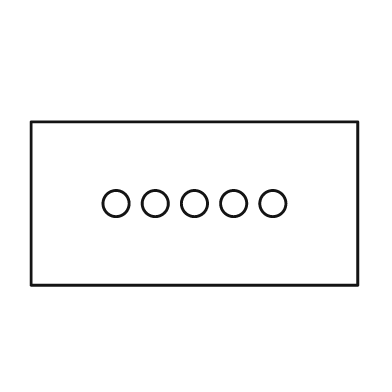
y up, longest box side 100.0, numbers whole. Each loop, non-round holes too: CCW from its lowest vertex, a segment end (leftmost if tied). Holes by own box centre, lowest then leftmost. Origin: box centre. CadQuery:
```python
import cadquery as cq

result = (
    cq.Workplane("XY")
    .moveTo(-50.0, -25.0)
    .lineTo(50.0, -25.0)
    .lineTo(50.0, 25.0)
    .lineTo(-50.0, 25.0)
    .close()
    .moveTo(-24.0, 0.0)
    .circle(4.0)
    .moveTo(-12.0, 0.0)
    .circle(4.0)
    .moveTo(0.0, 0.0)
    .circle(4.0)
    .moveTo(12.0, 0.0)
    .circle(4.0)
    .moveTo(24.0, 0.0)
    .circle(4.0)
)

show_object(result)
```